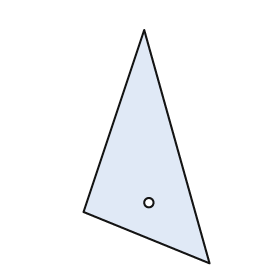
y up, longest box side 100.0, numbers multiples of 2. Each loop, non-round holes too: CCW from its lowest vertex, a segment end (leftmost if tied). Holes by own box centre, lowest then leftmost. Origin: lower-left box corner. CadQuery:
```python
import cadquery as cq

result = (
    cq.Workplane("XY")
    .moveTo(54.0, 0.0)
    .lineTo(26.0, 100.0)
    .lineTo(0.0, 22.0)
    .close()
    .moveTo(28.0, 26.0)
    .circle(2.0)
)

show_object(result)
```